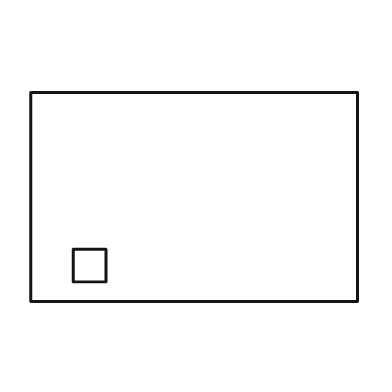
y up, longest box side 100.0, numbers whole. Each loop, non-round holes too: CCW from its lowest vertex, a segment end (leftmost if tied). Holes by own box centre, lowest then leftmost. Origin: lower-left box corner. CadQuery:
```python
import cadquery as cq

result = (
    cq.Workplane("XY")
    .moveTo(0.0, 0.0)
    .lineTo(100.0, 0.0)
    .lineTo(100.0, 64.0)
    .lineTo(0.0, 64.0)
    .close()
    .moveTo(13.0, 6.0)
    .lineTo(23.0, 6.0)
    .lineTo(23.0, 16.0)
    .lineTo(13.0, 16.0)
    .close()
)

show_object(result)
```